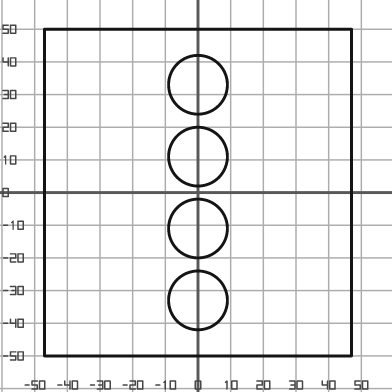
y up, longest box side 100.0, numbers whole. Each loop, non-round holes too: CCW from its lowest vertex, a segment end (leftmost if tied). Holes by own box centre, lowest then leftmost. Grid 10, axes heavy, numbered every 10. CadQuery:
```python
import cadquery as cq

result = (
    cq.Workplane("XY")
    .moveTo(-47.0, -50.0)
    .lineTo(47.0, -50.0)
    .lineTo(47.0, 50.0)
    .lineTo(-47.0, 50.0)
    .close()
    .moveTo(0.0, -33.0)
    .circle(9.0)
    .moveTo(0.0, -11.0)
    .circle(9.0)
    .moveTo(0.0, 11.0)
    .circle(9.0)
    .moveTo(0.0, 33.0)
    .circle(9.0)
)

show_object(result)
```